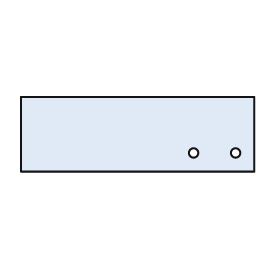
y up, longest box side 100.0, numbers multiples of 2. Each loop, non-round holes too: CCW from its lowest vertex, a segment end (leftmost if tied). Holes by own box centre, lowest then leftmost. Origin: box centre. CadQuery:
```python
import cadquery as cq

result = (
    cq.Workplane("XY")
    .moveTo(-50.0, -16.0)
    .lineTo(50.0, -16.0)
    .lineTo(50.0, 16.0)
    .lineTo(-50.0, 16.0)
    .close()
    .moveTo(24.0, -8.0)
    .circle(2.0)
    .moveTo(42.0, -8.0)
    .circle(2.0)
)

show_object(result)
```